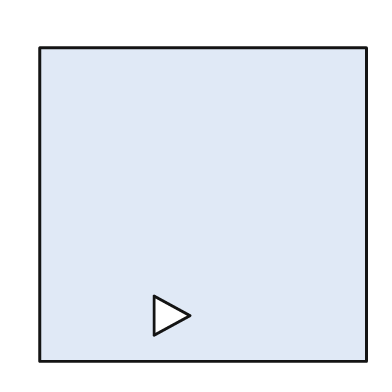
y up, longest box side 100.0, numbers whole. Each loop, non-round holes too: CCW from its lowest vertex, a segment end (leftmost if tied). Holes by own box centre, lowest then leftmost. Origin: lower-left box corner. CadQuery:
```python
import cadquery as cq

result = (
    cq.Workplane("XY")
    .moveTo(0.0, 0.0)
    .lineTo(100.0, 0.0)
    .lineTo(100.0, 96.0)
    .lineTo(0.0, 96.0)
    .close()
    .moveTo(35.0, 8.0)
    .lineTo(46.0, 14.0)
    .lineTo(35.0, 20.0)
    .close()
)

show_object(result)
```